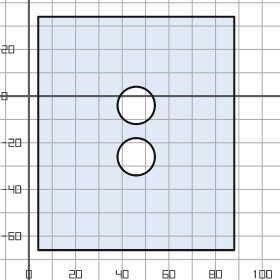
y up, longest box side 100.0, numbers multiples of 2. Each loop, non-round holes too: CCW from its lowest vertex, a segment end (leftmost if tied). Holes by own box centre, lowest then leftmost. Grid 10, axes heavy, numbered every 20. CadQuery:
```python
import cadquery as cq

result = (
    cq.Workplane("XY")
    .moveTo(4.0, -66.0)
    .lineTo(88.0, -66.0)
    .lineTo(88.0, 34.0)
    .lineTo(4.0, 34.0)
    .close()
    .moveTo(46.0, -26.0)
    .circle(8.0)
    .moveTo(46.0, -4.0)
    .circle(8.0)
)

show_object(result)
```